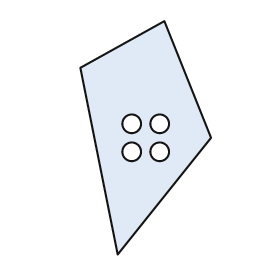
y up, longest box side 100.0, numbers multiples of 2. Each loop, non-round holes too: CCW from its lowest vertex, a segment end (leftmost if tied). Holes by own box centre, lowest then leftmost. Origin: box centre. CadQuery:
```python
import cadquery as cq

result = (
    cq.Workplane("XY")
    .moveTo(-12.0, -50.0)
    .lineTo(28.0, 0.0)
    .lineTo(8.0, 50.0)
    .lineTo(-28.0, 30.0)
    .close()
    .moveTo(-6.0, -6.0)
    .circle(4.0)
    .moveTo(6.0, -6.0)
    .circle(4.0)
    .moveTo(-6.0, 6.0)
    .circle(4.0)
    .moveTo(6.0, 6.0)
    .circle(4.0)
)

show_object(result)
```